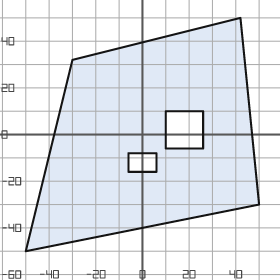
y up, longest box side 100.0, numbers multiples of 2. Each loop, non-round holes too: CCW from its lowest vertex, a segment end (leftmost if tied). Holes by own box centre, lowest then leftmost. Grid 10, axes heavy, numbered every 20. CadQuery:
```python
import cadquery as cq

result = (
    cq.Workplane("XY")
    .moveTo(-50.0, -50.0)
    .lineTo(50.0, -30.0)
    .lineTo(42.0, 50.0)
    .lineTo(-30.0, 32.0)
    .close()
    .moveTo(-6.0, -16.0)
    .lineTo(6.0, -16.0)
    .lineTo(6.0, -8.0)
    .lineTo(-6.0, -8.0)
    .close()
    .moveTo(10.0, -6.0)
    .lineTo(26.0, -6.0)
    .lineTo(26.0, 10.0)
    .lineTo(10.0, 10.0)
    .close()
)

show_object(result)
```